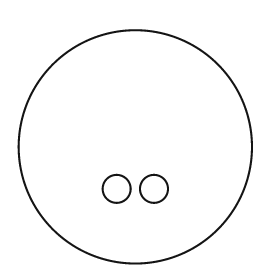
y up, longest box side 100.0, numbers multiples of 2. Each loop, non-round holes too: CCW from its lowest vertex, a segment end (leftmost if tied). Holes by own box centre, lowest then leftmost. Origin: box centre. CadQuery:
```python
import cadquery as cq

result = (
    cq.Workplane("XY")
    .moveTo(0.0, 0.0)
    .circle(50.0)
    .moveTo(-8.0, -18.0)
    .circle(6.0)
    .moveTo(8.0, -18.0)
    .circle(6.0)
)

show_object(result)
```